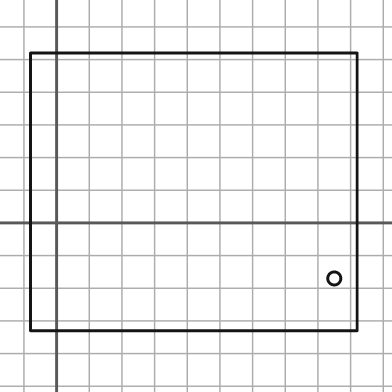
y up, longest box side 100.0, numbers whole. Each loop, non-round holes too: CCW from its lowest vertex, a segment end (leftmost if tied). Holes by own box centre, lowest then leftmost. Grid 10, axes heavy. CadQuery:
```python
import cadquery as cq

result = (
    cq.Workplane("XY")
    .moveTo(-8.0, -33.0)
    .lineTo(92.0, -33.0)
    .lineTo(92.0, 52.0)
    .lineTo(-8.0, 52.0)
    .close()
    .moveTo(85.0, -17.0)
    .circle(2.0)
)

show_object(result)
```